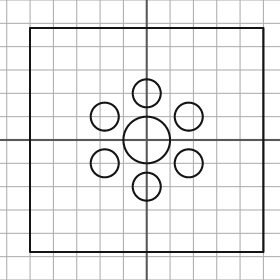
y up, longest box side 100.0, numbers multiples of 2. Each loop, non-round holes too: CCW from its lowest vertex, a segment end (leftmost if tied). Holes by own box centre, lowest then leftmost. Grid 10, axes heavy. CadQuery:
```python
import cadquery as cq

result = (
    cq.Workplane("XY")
    .moveTo(-50.0, -48.0)
    .lineTo(50.0, -48.0)
    .lineTo(50.0, 48.0)
    .lineTo(-50.0, 48.0)
    .close()
    .moveTo(0.0, -20.0)
    .circle(6.0)
    .moveTo(-18.0, -10.0)
    .circle(6.0)
    .moveTo(18.0, -10.0)
    .circle(6.0)
    .moveTo(0.0, 0.0)
    .circle(10.0)
    .moveTo(-18.0, 10.0)
    .circle(6.0)
    .moveTo(18.0, 10.0)
    .circle(6.0)
    .moveTo(0.0, 20.0)
    .circle(6.0)
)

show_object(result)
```